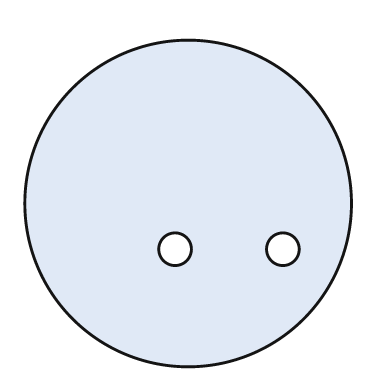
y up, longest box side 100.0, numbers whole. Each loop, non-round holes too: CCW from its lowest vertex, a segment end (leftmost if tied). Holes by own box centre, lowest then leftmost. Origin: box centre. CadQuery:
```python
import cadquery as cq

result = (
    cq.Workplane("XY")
    .moveTo(0.0, 0.0)
    .circle(50.0)
    .moveTo(-4.0, -14.0)
    .circle(5.0)
    .moveTo(29.0, -14.0)
    .circle(5.0)
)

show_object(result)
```